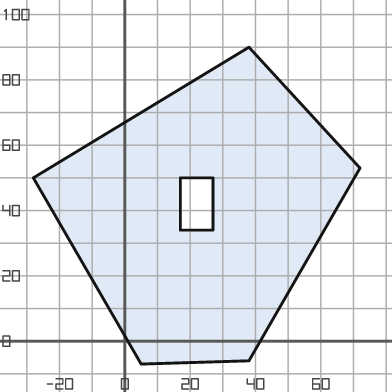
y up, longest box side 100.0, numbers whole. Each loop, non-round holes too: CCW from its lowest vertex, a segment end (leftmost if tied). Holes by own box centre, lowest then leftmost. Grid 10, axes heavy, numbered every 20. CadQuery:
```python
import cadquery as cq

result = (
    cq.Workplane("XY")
    .moveTo(5.0, -7.0)
    .lineTo(38.0, -6.0)
    .lineTo(72.0, 53.0)
    .lineTo(38.0, 90.0)
    .lineTo(-28.0, 50.0)
    .close()
    .moveTo(17.0, 34.0)
    .lineTo(27.0, 34.0)
    .lineTo(27.0, 50.0)
    .lineTo(17.0, 50.0)
    .close()
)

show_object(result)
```